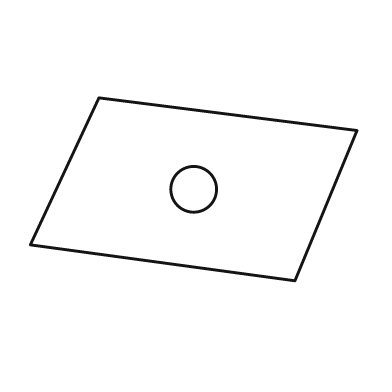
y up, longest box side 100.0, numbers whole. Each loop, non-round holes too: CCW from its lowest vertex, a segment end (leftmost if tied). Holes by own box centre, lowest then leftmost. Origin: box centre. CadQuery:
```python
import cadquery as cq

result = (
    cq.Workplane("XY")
    .moveTo(31.0, -28.0)
    .lineTo(50.0, 18.0)
    .lineTo(-29.0, 28.0)
    .lineTo(-50.0, -17.0)
    .close()
    .moveTo(0.0, 0.0)
    .circle(7.0)
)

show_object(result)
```